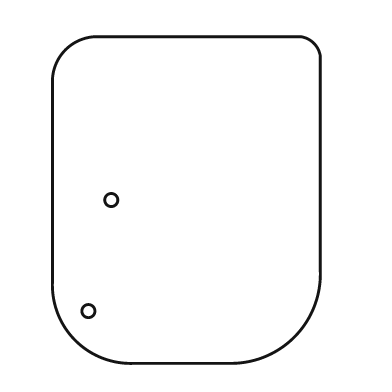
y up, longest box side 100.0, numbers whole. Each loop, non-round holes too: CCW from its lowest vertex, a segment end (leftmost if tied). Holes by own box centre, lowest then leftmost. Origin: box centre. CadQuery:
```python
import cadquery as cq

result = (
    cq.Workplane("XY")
    .moveTo(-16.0, -50.0)
    .lineTo(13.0, -50.0)
    .threePointArc((33.0, -42.0), (41.0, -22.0))
    .lineTo(41.0, 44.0)
    .threePointArc((39.0, 48.0), (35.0, 50.0))
    .lineTo(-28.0, 50.0)
    .threePointArc((-37.0, 46.0), (-41.0, 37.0))
    .lineTo(-41.0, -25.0)
    .threePointArc((-34.0, -43.0), (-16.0, -50.0))
    .close()
    .moveTo(-30.0, -34.0)
    .circle(2.0)
    .moveTo(-23.0, 0.0)
    .circle(2.0)
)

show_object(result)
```